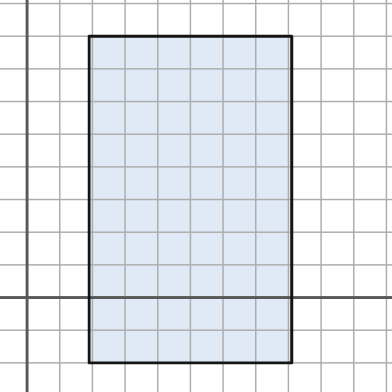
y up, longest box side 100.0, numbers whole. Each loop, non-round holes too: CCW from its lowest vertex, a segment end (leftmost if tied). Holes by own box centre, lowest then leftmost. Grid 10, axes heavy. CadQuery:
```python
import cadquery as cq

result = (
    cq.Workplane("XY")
    .moveTo(19.0, -20.0)
    .lineTo(81.0, -20.0)
    .lineTo(81.0, 80.0)
    .lineTo(19.0, 80.0)
    .close()
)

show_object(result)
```